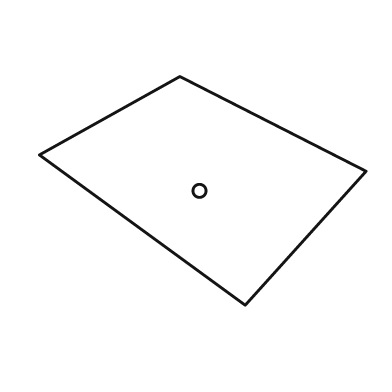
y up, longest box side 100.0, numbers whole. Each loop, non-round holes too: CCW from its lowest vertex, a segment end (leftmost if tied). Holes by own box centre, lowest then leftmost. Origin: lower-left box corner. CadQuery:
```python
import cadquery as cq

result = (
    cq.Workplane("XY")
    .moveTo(63.0, 0.0)
    .lineTo(100.0, 41.0)
    .lineTo(43.0, 70.0)
    .lineTo(0.0, 46.0)
    .close()
    .moveTo(49.0, 35.0)
    .circle(2.0)
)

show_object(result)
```